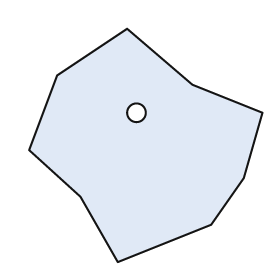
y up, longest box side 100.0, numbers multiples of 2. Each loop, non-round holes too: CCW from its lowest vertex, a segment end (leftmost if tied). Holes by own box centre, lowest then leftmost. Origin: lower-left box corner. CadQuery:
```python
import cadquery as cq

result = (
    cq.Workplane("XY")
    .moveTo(38.0, 0.0)
    .lineTo(78.0, 16.0)
    .lineTo(92.0, 36.0)
    .lineTo(100.0, 64.0)
    .lineTo(70.0, 76.0)
    .lineTo(42.0, 100.0)
    .lineTo(12.0, 80.0)
    .lineTo(0.0, 48.0)
    .lineTo(22.0, 28.0)
    .close()
    .moveTo(46.0, 64.0)
    .circle(4.0)
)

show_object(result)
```